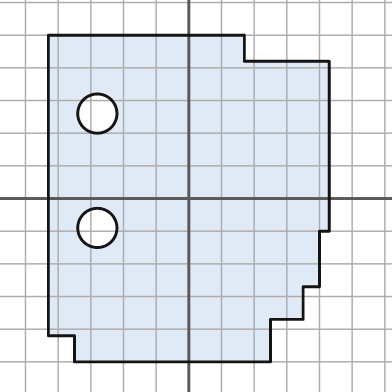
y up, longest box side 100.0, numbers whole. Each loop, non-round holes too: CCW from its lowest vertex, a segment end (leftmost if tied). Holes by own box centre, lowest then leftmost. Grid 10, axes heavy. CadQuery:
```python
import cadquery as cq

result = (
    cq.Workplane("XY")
    .moveTo(-35.0, -50.0)
    .lineTo(25.0, -50.0)
    .lineTo(25.0, -37.0)
    .lineTo(35.0, -37.0)
    .lineTo(35.0, -27.0)
    .lineTo(40.0, -27.0)
    .lineTo(40.0, -10.0)
    .lineTo(43.0, -10.0)
    .lineTo(43.0, 42.0)
    .lineTo(17.0, 42.0)
    .lineTo(17.0, 50.0)
    .lineTo(-43.0, 50.0)
    .lineTo(-43.0, -42.0)
    .lineTo(-35.0, -42.0)
    .close()
    .moveTo(-28.0, -9.0)
    .circle(6.0)
    .moveTo(-28.0, 26.0)
    .circle(6.0)
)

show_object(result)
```